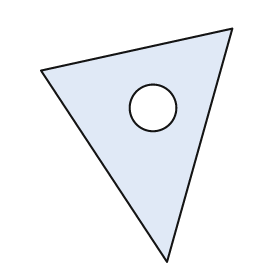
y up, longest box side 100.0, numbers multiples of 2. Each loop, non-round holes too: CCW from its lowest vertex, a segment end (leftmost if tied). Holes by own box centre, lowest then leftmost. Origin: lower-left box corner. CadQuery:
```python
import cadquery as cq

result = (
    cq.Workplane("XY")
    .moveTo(54.0, 0.0)
    .lineTo(82.0, 100.0)
    .lineTo(0.0, 82.0)
    .close()
    .moveTo(48.0, 66.0)
    .circle(10.0)
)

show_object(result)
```